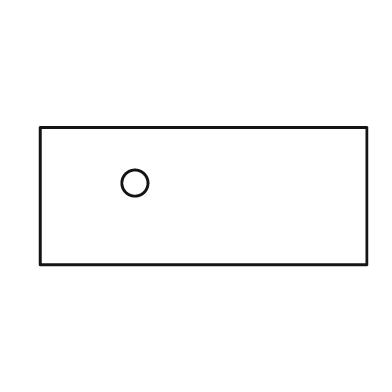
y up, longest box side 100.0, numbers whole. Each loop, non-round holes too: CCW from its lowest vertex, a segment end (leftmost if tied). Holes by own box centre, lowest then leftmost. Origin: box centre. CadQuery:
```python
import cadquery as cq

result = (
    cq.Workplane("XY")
    .moveTo(-50.0, -21.0)
    .lineTo(50.0, -21.0)
    .lineTo(50.0, 21.0)
    .lineTo(-50.0, 21.0)
    .close()
    .moveTo(-21.0, 4.0)
    .circle(4.0)
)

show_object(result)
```